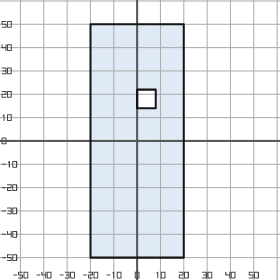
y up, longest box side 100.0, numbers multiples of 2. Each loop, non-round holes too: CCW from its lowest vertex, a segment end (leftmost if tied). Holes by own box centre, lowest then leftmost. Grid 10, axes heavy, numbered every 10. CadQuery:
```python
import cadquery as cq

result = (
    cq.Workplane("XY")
    .moveTo(-20.0, -50.0)
    .lineTo(20.0, -50.0)
    .lineTo(20.0, 50.0)
    .lineTo(-20.0, 50.0)
    .close()
    .moveTo(0.0, 14.0)
    .lineTo(8.0, 14.0)
    .lineTo(8.0, 22.0)
    .lineTo(0.0, 22.0)
    .close()
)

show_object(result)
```